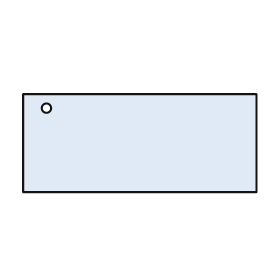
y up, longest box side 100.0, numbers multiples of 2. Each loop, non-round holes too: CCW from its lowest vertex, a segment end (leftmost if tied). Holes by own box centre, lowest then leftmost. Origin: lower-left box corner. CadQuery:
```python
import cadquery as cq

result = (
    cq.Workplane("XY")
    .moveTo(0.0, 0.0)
    .lineTo(100.0, 0.0)
    .lineTo(100.0, 42.0)
    .lineTo(0.0, 42.0)
    .close()
    .moveTo(10.0, 36.0)
    .circle(2.0)
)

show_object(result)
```